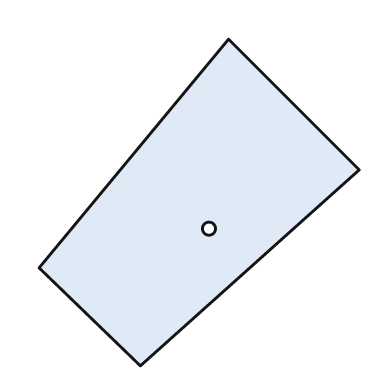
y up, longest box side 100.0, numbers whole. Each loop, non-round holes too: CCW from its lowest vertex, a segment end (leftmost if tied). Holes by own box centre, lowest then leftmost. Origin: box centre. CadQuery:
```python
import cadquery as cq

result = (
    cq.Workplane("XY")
    .moveTo(-18.0, -50.0)
    .lineTo(49.0, 10.0)
    .lineTo(9.0, 50.0)
    .lineTo(-49.0, -20.0)
    .close()
    .moveTo(3.0, -8.0)
    .circle(2.0)
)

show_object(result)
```